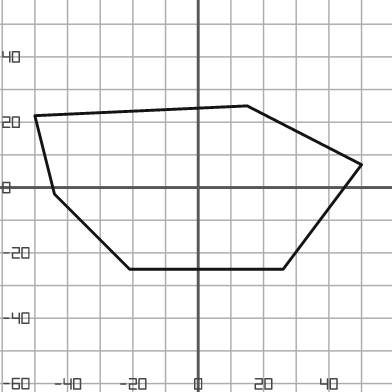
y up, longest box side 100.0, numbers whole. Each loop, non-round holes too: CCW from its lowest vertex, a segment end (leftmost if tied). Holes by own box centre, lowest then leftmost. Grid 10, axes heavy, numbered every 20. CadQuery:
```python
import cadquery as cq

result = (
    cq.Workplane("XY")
    .moveTo(-21.0, -25.0)
    .lineTo(26.0, -25.0)
    .lineTo(50.0, 7.0)
    .lineTo(15.0, 25.0)
    .lineTo(-50.0, 22.0)
    .lineTo(-44.0, -2.0)
    .close()
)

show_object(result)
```